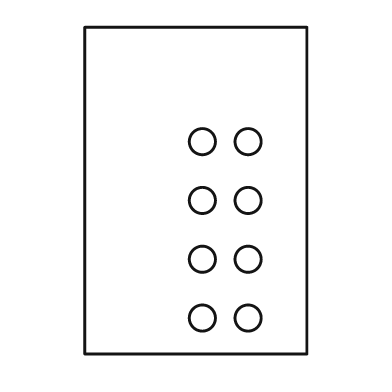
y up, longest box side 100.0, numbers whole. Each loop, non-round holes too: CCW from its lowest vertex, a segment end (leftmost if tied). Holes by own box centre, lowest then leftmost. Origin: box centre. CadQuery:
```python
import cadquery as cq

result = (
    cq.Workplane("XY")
    .moveTo(-34.0, -50.0)
    .lineTo(34.0, -50.0)
    .lineTo(34.0, 50.0)
    .lineTo(-34.0, 50.0)
    .close()
    .moveTo(2.0, -39.0)
    .circle(4.0)
    .moveTo(16.0, -39.0)
    .circle(4.0)
    .moveTo(2.0, -21.0)
    .circle(4.0)
    .moveTo(16.0, -21.0)
    .circle(4.0)
    .moveTo(2.0, -3.0)
    .circle(4.0)
    .moveTo(16.0, -3.0)
    .circle(4.0)
    .moveTo(2.0, 15.0)
    .circle(4.0)
    .moveTo(16.0, 15.0)
    .circle(4.0)
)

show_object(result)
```